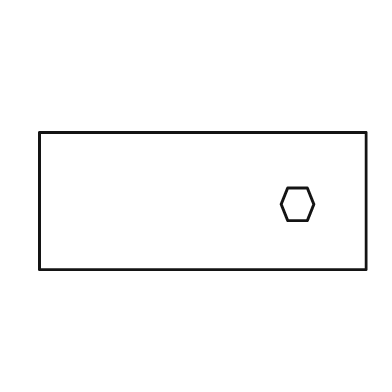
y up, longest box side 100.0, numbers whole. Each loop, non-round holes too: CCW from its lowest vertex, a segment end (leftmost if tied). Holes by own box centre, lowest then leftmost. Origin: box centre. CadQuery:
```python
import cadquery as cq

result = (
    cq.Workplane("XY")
    .moveTo(-50.0, -21.0)
    .lineTo(50.0, -21.0)
    .lineTo(50.0, 21.0)
    .lineTo(-50.0, 21.0)
    .close()
    .moveTo(26.0, -6.0)
    .lineTo(32.0, -6.0)
    .lineTo(34.0, -1.0)
    .lineTo(32.0, 4.0)
    .lineTo(26.0, 4.0)
    .lineTo(24.0, -1.0)
    .close()
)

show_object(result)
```